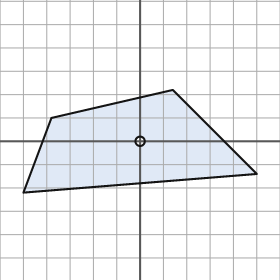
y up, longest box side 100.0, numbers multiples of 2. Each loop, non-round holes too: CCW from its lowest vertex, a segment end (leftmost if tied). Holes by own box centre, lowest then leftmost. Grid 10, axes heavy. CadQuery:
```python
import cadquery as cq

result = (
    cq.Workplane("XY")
    .moveTo(-50.0, -22.0)
    .lineTo(50.0, -14.0)
    .lineTo(14.0, 22.0)
    .lineTo(-38.0, 10.0)
    .close()
    .moveTo(0.0, 0.0)
    .circle(2.0)
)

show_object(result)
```